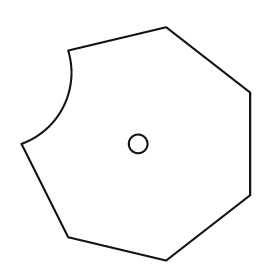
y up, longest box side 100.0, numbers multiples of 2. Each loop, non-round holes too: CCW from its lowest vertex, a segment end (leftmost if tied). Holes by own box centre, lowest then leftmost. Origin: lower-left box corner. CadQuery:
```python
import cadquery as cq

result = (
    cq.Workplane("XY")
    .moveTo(62.0, 0.0)
    .lineTo(98.0, 28.0)
    .lineTo(98.0, 72.0)
    .lineTo(62.0, 100.0)
    .lineTo(20.0, 90.0)
    .threePointArc((18.0, 66.0), (0.0, 50.0))
    .lineTo(20.0, 10.0)
    .close()
    .moveTo(50.0, 50.0)
    .circle(4.0)
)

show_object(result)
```